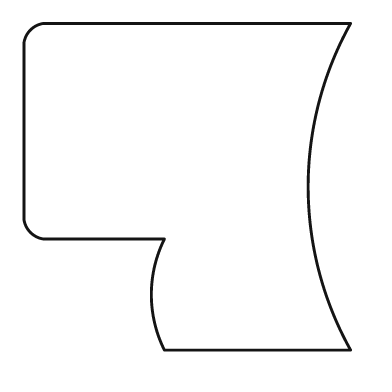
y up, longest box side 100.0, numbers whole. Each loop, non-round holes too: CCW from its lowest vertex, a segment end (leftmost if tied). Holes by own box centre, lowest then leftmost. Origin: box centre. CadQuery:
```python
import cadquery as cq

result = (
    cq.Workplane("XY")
    .moveTo(-7.0, -50.0)
    .lineTo(50.0, -50.0)
    .threePointArc((37.0, 0.0), (50.0, 50.0))
    .lineTo(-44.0, 50.0)
    .threePointArc((-48.0, 48.0), (-50.0, 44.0))
    .lineTo(-50.0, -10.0)
    .threePointArc((-48.0, -14.0), (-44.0, -16.0))
    .lineTo(-7.0, -16.0)
    .threePointArc((-11.0, -33.0), (-7.0, -50.0))
    .close()
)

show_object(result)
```